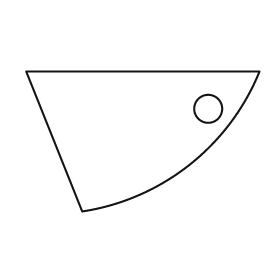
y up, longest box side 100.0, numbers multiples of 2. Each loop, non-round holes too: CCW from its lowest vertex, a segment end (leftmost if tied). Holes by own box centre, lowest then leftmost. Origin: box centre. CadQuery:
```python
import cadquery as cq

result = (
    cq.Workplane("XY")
    .moveTo(-26.0, -30.0)
    .threePointArc((20.0, -10.0), (50.0, 30.0))
    .lineTo(-50.0, 30.0)
    .close()
    .moveTo(28.0, 14.0)
    .circle(6.0)
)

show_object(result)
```